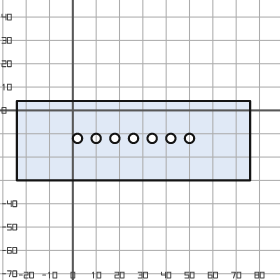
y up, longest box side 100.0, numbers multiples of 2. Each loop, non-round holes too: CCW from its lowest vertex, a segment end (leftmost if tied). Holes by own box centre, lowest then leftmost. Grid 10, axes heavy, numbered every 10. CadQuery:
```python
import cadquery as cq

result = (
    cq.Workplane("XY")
    .moveTo(-24.0, -30.0)
    .lineTo(76.0, -30.0)
    .lineTo(76.0, 4.0)
    .lineTo(-24.0, 4.0)
    .close()
    .moveTo(2.0, -12.0)
    .circle(2.0)
    .moveTo(10.0, -12.0)
    .circle(2.0)
    .moveTo(18.0, -12.0)
    .circle(2.0)
    .moveTo(26.0, -12.0)
    .circle(2.0)
    .moveTo(34.0, -12.0)
    .circle(2.0)
    .moveTo(42.0, -12.0)
    .circle(2.0)
    .moveTo(50.0, -12.0)
    .circle(2.0)
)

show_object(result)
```